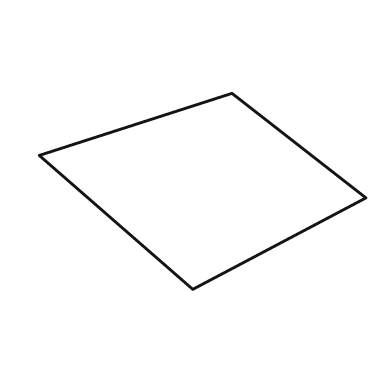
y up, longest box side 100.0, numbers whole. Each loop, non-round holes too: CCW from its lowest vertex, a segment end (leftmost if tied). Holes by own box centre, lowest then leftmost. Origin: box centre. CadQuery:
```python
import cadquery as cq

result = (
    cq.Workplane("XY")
    .moveTo(-3.0, -30.0)
    .lineTo(50.0, -2.0)
    .lineTo(9.0, 30.0)
    .lineTo(-50.0, 11.0)
    .close()
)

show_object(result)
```